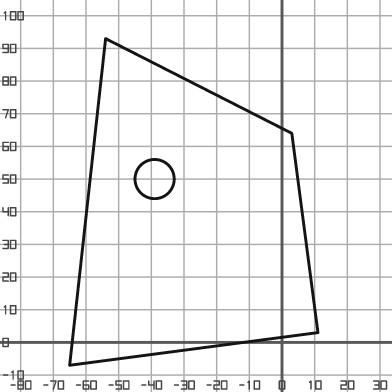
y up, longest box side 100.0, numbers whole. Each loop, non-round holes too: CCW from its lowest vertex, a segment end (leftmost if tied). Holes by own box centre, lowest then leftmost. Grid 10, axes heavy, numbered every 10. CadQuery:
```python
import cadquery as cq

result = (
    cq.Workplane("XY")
    .moveTo(-65.0, -7.0)
    .lineTo(11.0, 3.0)
    .lineTo(3.0, 64.0)
    .lineTo(-54.0, 93.0)
    .close()
    .moveTo(-39.0, 50.0)
    .circle(6.0)
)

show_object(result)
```